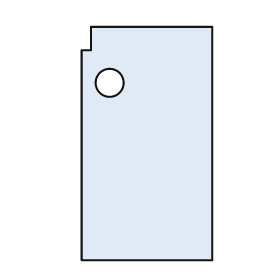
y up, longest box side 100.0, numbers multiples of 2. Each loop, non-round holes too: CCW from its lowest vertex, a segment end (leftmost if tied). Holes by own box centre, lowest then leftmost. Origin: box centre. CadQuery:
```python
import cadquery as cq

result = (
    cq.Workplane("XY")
    .moveTo(-28.0, -50.0)
    .lineTo(28.0, -50.0)
    .lineTo(28.0, 50.0)
    .lineTo(-24.0, 50.0)
    .lineTo(-24.0, 40.0)
    .lineTo(-28.0, 40.0)
    .close()
    .moveTo(-16.0, 26.0)
    .circle(6.0)
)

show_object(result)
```